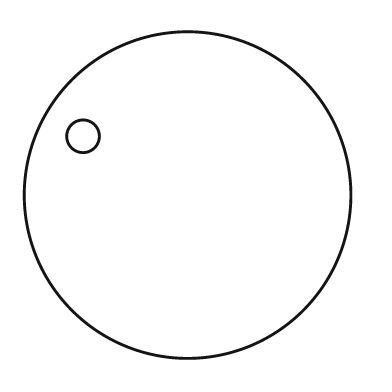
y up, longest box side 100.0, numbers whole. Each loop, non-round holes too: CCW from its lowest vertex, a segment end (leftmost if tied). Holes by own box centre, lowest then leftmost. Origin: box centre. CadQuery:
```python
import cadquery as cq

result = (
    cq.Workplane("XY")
    .moveTo(0.0, 0.0)
    .circle(50.0)
    .moveTo(-32.0, 18.0)
    .circle(5.0)
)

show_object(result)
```